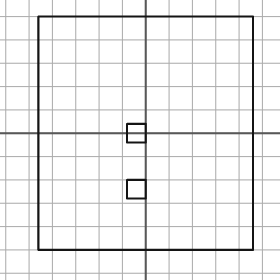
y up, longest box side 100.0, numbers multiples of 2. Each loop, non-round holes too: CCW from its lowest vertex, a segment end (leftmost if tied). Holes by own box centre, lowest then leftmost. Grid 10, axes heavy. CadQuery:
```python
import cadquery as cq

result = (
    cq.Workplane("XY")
    .moveTo(-46.0, -50.0)
    .lineTo(46.0, -50.0)
    .lineTo(46.0, 50.0)
    .lineTo(-46.0, 50.0)
    .close()
    .moveTo(-8.0, -28.0)
    .lineTo(0.0, -28.0)
    .lineTo(0.0, -20.0)
    .lineTo(-8.0, -20.0)
    .close()
    .moveTo(-8.0, -4.0)
    .lineTo(0.0, -4.0)
    .lineTo(0.0, 4.0)
    .lineTo(-8.0, 4.0)
    .close()
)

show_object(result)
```